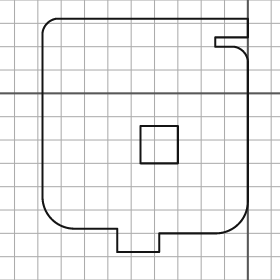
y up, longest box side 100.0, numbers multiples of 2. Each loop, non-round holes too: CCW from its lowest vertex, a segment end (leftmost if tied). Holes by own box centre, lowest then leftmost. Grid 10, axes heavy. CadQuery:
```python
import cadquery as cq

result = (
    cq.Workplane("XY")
    .moveTo(-56.0, -68.0)
    .lineTo(-38.0, -68.0)
    .lineTo(-38.0, -60.0)
    .lineTo(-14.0, -60.0)
    .threePointArc((-4.0, -56.0), (0.0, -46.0))
    .lineTo(0.0, 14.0)
    .threePointArc((-2.0, 18.0), (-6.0, 20.0))
    .lineTo(-14.0, 20.0)
    .lineTo(-14.0, 24.0)
    .lineTo(0.0, 24.0)
    .lineTo(0.0, 32.0)
    .lineTo(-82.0, 32.0)
    .threePointArc((-86.0, 30.0), (-88.0, 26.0))
    .lineTo(-88.0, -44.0)
    .threePointArc((-84.0, -54.0), (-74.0, -58.0))
    .lineTo(-56.0, -58.0)
    .close()
    .moveTo(-46.0, -30.0)
    .lineTo(-30.0, -30.0)
    .lineTo(-30.0, -14.0)
    .lineTo(-46.0, -14.0)
    .close()
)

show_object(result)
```